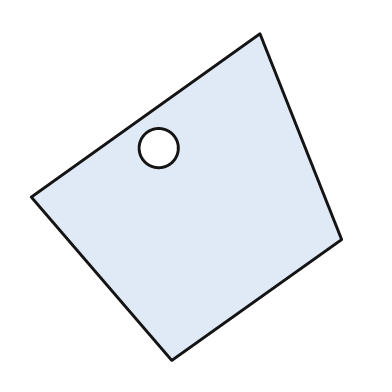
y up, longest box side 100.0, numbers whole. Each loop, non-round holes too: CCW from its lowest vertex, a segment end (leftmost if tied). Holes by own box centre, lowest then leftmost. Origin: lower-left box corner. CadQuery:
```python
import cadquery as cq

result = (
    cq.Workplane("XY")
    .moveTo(43.0, 0.0)
    .lineTo(95.0, 37.0)
    .lineTo(70.0, 100.0)
    .lineTo(0.0, 50.0)
    .close()
    .moveTo(39.0, 65.0)
    .circle(6.0)
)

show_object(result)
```